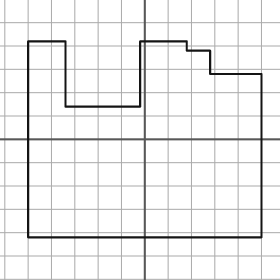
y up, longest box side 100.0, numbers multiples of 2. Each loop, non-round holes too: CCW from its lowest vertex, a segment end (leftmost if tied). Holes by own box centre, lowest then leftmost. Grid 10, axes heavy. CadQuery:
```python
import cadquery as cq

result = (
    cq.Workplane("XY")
    .moveTo(-50.0, -42.0)
    .lineTo(50.0, -42.0)
    .lineTo(50.0, 28.0)
    .lineTo(28.0, 28.0)
    .lineTo(28.0, 38.0)
    .lineTo(18.0, 38.0)
    .lineTo(18.0, 42.0)
    .lineTo(-2.0, 42.0)
    .lineTo(-2.0, 14.0)
    .lineTo(-34.0, 14.0)
    .lineTo(-34.0, 42.0)
    .lineTo(-50.0, 42.0)
    .close()
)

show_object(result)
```